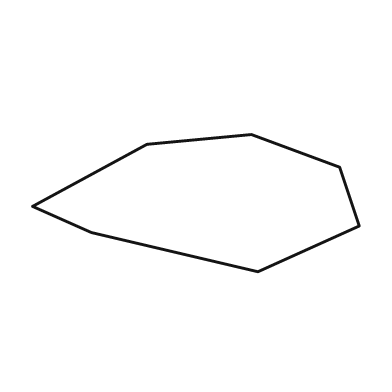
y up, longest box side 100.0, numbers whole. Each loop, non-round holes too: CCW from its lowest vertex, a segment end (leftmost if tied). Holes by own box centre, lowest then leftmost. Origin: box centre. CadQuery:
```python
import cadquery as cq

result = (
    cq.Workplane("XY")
    .moveTo(19.0, -21.0)
    .lineTo(50.0, -7.0)
    .lineTo(44.0, 11.0)
    .lineTo(17.0, 21.0)
    .lineTo(-15.0, 18.0)
    .lineTo(-50.0, -1.0)
    .lineTo(-32.0, -9.0)
    .close()
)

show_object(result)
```